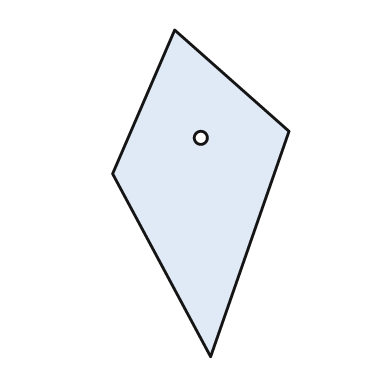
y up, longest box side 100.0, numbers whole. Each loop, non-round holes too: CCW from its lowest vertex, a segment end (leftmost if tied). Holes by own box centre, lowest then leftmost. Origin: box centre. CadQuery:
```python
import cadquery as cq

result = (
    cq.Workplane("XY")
    .moveTo(3.0, -50.0)
    .lineTo(27.0, 19.0)
    .lineTo(-8.0, 50.0)
    .lineTo(-27.0, 6.0)
    .close()
    .moveTo(0.0, 17.0)
    .circle(2.0)
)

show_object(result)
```